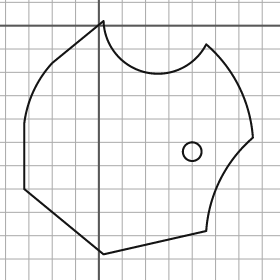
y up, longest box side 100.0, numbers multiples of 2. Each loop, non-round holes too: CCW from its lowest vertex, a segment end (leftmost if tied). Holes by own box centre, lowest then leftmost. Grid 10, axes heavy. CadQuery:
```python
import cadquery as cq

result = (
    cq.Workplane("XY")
    .moveTo(2.0, -98.0)
    .lineTo(46.0, -88.0)
    .threePointArc((52.0, -66.0), (66.0, -48.0))
    .threePointArc((60.0, -26.0), (46.0, -8.0))
    .threePointArc((20.0, -20.0), (2.0, 2.0))
    .lineTo(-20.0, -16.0)
    .threePointArc((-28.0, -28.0), (-32.0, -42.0))
    .lineTo(-32.0, -70.0)
    .close()
    .moveTo(40.0, -54.0)
    .circle(4.0)
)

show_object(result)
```